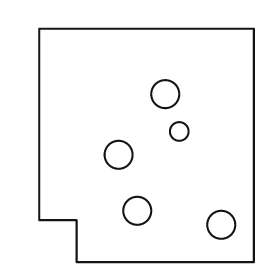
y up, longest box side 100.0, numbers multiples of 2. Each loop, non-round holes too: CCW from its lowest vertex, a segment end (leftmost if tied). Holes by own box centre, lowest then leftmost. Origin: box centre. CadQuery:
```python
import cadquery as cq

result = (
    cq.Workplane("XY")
    .moveTo(-30.0, -50.0)
    .lineTo(46.0, -50.0)
    .lineTo(46.0, 50.0)
    .lineTo(-46.0, 50.0)
    .lineTo(-46.0, -32.0)
    .lineTo(-30.0, -32.0)
    .close()
    .moveTo(32.0, -34.0)
    .circle(6.0)
    .moveTo(-4.0, -28.0)
    .circle(6.0)
    .moveTo(-12.0, -4.0)
    .circle(6.0)
    .moveTo(14.0, 6.0)
    .circle(4.0)
    .moveTo(8.0, 22.0)
    .circle(6.0)
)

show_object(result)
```